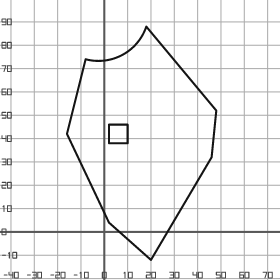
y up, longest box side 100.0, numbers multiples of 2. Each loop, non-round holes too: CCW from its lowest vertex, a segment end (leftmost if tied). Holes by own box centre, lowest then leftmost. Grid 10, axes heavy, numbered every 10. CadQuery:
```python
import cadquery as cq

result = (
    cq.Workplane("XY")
    .moveTo(20.0, -12.0)
    .lineTo(46.0, 32.0)
    .lineTo(48.0, 52.0)
    .lineTo(18.0, 88.0)
    .threePointArc((8.0, 76.0), (-8.0, 74.0))
    .lineTo(-16.0, 42.0)
    .lineTo(2.0, 4.0)
    .close()
    .moveTo(2.0, 38.0)
    .lineTo(10.0, 38.0)
    .lineTo(10.0, 46.0)
    .lineTo(2.0, 46.0)
    .close()
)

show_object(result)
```